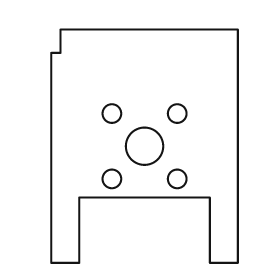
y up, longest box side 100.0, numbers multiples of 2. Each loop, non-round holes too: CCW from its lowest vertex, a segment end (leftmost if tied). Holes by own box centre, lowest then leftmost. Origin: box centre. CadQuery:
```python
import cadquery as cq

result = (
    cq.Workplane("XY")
    .moveTo(-40.0, -50.0)
    .lineTo(-28.0, -50.0)
    .lineTo(-28.0, -22.0)
    .lineTo(28.0, -22.0)
    .lineTo(28.0, -50.0)
    .lineTo(40.0, -50.0)
    .lineTo(40.0, 50.0)
    .lineTo(-36.0, 50.0)
    .lineTo(-36.0, 40.0)
    .lineTo(-40.0, 40.0)
    .close()
    .moveTo(-14.0, -14.0)
    .circle(4.0)
    .moveTo(14.0, -14.0)
    .circle(4.0)
    .moveTo(0.0, 0.0)
    .circle(8.0)
    .moveTo(-14.0, 14.0)
    .circle(4.0)
    .moveTo(14.0, 14.0)
    .circle(4.0)
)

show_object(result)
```